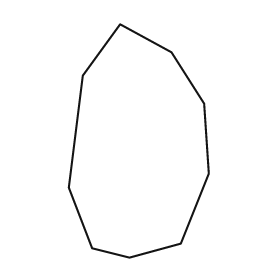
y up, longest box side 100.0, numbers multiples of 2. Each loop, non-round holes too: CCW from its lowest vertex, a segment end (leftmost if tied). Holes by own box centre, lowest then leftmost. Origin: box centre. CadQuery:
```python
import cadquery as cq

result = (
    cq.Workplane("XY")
    .moveTo(-4.0, -50.0)
    .lineTo(18.0, -44.0)
    .lineTo(30.0, -14.0)
    .lineTo(28.0, 16.0)
    .lineTo(14.0, 38.0)
    .lineTo(-8.0, 50.0)
    .lineTo(-24.0, 28.0)
    .lineTo(-30.0, -20.0)
    .lineTo(-20.0, -46.0)
    .close()
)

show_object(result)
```